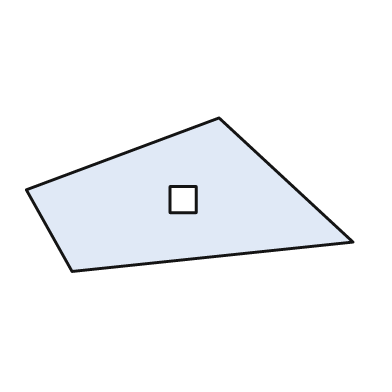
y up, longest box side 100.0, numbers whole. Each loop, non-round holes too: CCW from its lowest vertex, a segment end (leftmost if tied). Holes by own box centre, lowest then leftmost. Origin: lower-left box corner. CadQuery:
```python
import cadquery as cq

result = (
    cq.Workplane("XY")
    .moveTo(14.0, 0.0)
    .lineTo(100.0, 9.0)
    .lineTo(59.0, 47.0)
    .lineTo(0.0, 25.0)
    .close()
    .moveTo(44.0, 18.0)
    .lineTo(52.0, 18.0)
    .lineTo(52.0, 26.0)
    .lineTo(44.0, 26.0)
    .close()
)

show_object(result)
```